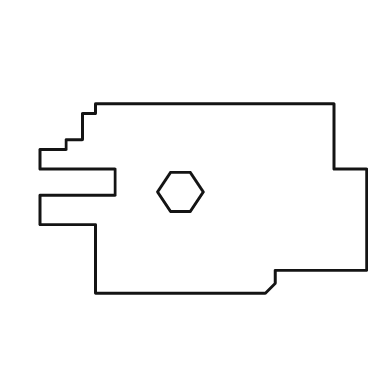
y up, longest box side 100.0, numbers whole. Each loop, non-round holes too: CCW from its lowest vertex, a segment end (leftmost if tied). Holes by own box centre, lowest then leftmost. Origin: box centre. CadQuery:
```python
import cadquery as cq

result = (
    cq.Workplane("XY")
    .moveTo(-33.0, -29.0)
    .lineTo(19.0, -29.0)
    .lineTo(22.0, -26.0)
    .lineTo(22.0, -22.0)
    .lineTo(50.0, -22.0)
    .lineTo(50.0, 9.0)
    .lineTo(40.0, 9.0)
    .lineTo(40.0, 29.0)
    .lineTo(-33.0, 29.0)
    .lineTo(-33.0, 26.0)
    .lineTo(-37.0, 26.0)
    .lineTo(-37.0, 18.0)
    .lineTo(-42.0, 18.0)
    .lineTo(-42.0, 15.0)
    .lineTo(-50.0, 15.0)
    .lineTo(-50.0, 9.0)
    .lineTo(-27.0, 9.0)
    .lineTo(-27.0, 1.0)
    .lineTo(-50.0, 1.0)
    .lineTo(-50.0, -8.0)
    .lineTo(-33.0, -8.0)
    .close()
    .moveTo(-10.0, -4.0)
    .lineTo(-4.0, -4.0)
    .lineTo(0.0, 2.0)
    .lineTo(-4.0, 8.0)
    .lineTo(-10.0, 8.0)
    .lineTo(-14.0, 2.0)
    .close()
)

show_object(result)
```